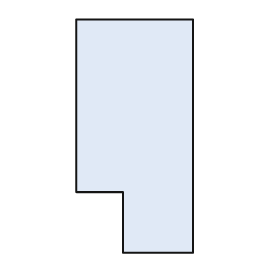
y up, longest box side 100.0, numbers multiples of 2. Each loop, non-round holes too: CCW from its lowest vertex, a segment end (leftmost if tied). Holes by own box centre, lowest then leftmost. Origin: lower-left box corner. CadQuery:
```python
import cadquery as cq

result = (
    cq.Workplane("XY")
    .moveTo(20.0, 0.0)
    .lineTo(50.0, 0.0)
    .lineTo(50.0, 100.0)
    .lineTo(0.0, 100.0)
    .lineTo(0.0, 26.0)
    .lineTo(20.0, 26.0)
    .close()
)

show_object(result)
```